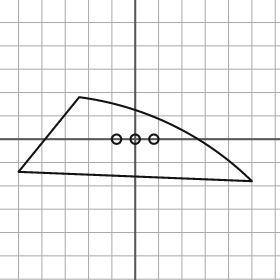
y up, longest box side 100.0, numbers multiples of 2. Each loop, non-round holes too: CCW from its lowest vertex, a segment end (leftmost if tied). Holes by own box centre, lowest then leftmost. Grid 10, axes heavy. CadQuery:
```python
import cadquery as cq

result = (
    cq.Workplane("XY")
    .moveTo(50.0, -18.0)
    .threePointArc((16.0, 6.0), (-24.0, 18.0))
    .lineTo(-50.0, -14.0)
    .close()
    .moveTo(-8.0, 0.0)
    .circle(2.0)
    .moveTo(0.0, 0.0)
    .circle(2.0)
    .moveTo(8.0, 0.0)
    .circle(2.0)
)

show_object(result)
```